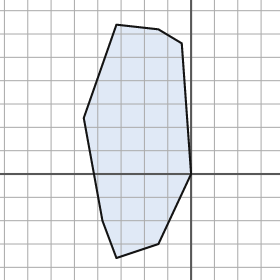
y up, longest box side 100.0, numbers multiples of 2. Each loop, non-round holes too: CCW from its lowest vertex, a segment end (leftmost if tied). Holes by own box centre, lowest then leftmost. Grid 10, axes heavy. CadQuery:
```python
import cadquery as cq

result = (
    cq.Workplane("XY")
    .moveTo(-32.0, -36.0)
    .lineTo(-14.0, -30.0)
    .lineTo(0.0, 0.0)
    .lineTo(-4.0, 56.0)
    .lineTo(-14.0, 62.0)
    .lineTo(-32.0, 64.0)
    .lineTo(-46.0, 24.0)
    .lineTo(-38.0, -20.0)
    .close()
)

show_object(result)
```